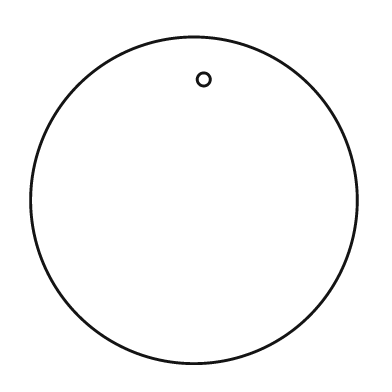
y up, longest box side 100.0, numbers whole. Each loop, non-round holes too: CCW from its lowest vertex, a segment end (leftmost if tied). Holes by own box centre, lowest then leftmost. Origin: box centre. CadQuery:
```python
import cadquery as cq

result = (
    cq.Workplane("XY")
    .moveTo(0.0, 0.0)
    .circle(50.0)
    .moveTo(3.0, 37.0)
    .circle(2.0)
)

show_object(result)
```